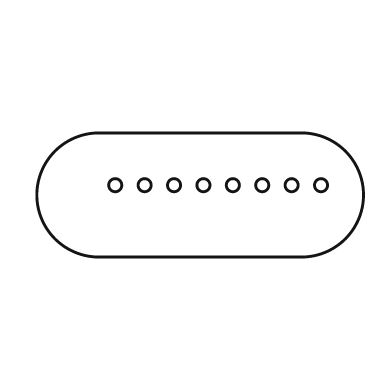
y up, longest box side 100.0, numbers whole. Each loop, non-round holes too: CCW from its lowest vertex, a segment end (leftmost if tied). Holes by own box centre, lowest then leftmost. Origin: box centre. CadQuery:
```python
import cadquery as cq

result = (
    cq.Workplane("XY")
    .moveTo(-31.0, -19.0)
    .lineTo(31.0, -19.0)
    .threePointArc((50.0, 0.0), (31.0, 19.0))
    .lineTo(-31.0, 19.0)
    .threePointArc((-50.0, 0.0), (-31.0, -19.0))
    .close()
    .moveTo(-26.0, 3.0)
    .circle(2.0)
    .moveTo(-17.0, 3.0)
    .circle(2.0)
    .moveTo(-8.0, 3.0)
    .circle(2.0)
    .moveTo(1.0, 3.0)
    .circle(2.0)
    .moveTo(10.0, 3.0)
    .circle(2.0)
    .moveTo(19.0, 3.0)
    .circle(2.0)
    .moveTo(28.0, 3.0)
    .circle(2.0)
    .moveTo(37.0, 3.0)
    .circle(2.0)
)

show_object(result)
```